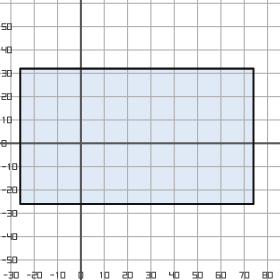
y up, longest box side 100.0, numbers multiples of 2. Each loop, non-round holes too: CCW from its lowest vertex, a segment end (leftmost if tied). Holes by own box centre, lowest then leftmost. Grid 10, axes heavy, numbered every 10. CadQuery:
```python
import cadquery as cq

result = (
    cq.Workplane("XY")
    .moveTo(-26.0, -26.0)
    .lineTo(74.0, -26.0)
    .lineTo(74.0, 32.0)
    .lineTo(-26.0, 32.0)
    .close()
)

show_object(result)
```